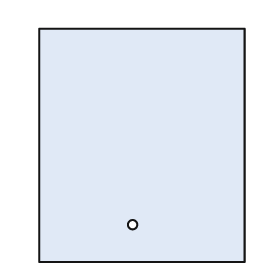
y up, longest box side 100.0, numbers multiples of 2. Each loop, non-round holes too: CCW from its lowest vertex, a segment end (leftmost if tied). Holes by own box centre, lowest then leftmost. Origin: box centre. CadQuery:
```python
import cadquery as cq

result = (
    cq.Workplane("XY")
    .moveTo(-44.0, -50.0)
    .lineTo(44.0, -50.0)
    .lineTo(44.0, 50.0)
    .lineTo(-44.0, 50.0)
    .close()
    .moveTo(-4.0, -34.0)
    .circle(2.0)
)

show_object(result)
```